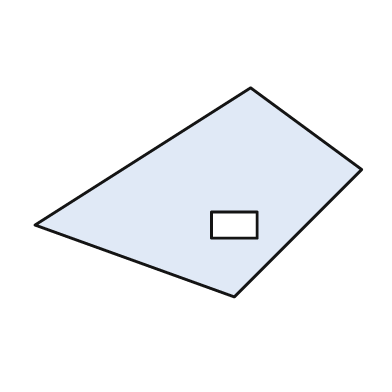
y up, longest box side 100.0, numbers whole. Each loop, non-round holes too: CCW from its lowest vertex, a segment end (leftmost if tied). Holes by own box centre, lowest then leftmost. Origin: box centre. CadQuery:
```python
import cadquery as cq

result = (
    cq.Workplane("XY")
    .moveTo(11.0, -32.0)
    .lineTo(50.0, 7.0)
    .lineTo(16.0, 32.0)
    .lineTo(-50.0, -10.0)
    .close()
    .moveTo(4.0, -14.0)
    .lineTo(18.0, -14.0)
    .lineTo(18.0, -6.0)
    .lineTo(4.0, -6.0)
    .close()
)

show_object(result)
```